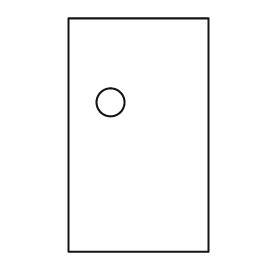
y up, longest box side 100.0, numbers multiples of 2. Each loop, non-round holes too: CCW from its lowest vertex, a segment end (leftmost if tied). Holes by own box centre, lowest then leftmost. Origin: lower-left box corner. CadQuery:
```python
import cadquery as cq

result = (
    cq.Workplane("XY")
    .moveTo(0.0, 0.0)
    .lineTo(60.0, 0.0)
    .lineTo(60.0, 100.0)
    .lineTo(0.0, 100.0)
    .close()
    .moveTo(18.0, 64.0)
    .circle(6.0)
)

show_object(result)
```